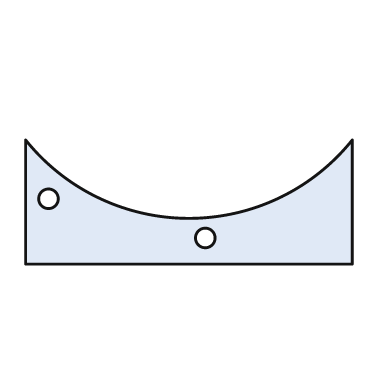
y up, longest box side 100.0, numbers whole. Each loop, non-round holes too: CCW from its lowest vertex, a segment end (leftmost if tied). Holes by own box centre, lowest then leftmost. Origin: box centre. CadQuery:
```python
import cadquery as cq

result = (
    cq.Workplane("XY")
    .moveTo(-50.0, -19.0)
    .lineTo(50.0, -19.0)
    .lineTo(50.0, 19.0)
    .threePointArc((0.0, -5.0), (-50.0, 19.0))
    .close()
    .moveTo(5.0, -11.0)
    .circle(3.0)
    .moveTo(-43.0, 1.0)
    .circle(3.0)
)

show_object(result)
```